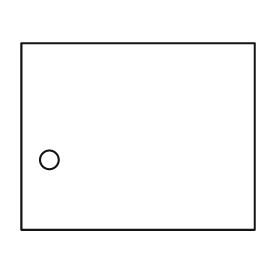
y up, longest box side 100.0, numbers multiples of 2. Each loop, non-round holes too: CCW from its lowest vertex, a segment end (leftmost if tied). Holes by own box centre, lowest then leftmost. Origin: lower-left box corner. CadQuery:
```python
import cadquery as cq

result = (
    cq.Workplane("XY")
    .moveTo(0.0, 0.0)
    .lineTo(100.0, 0.0)
    .lineTo(100.0, 80.0)
    .lineTo(0.0, 80.0)
    .close()
    .moveTo(12.0, 30.0)
    .circle(4.0)
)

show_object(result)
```